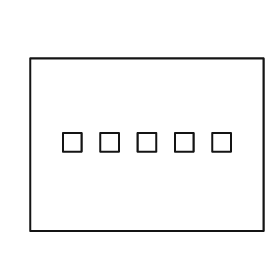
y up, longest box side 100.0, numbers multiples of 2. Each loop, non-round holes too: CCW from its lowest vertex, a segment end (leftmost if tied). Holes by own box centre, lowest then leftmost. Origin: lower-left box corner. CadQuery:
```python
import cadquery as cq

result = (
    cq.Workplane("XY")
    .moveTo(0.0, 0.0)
    .lineTo(100.0, 0.0)
    .lineTo(100.0, 74.0)
    .lineTo(0.0, 74.0)
    .close()
    .moveTo(14.0, 34.0)
    .lineTo(22.0, 34.0)
    .lineTo(22.0, 42.0)
    .lineTo(14.0, 42.0)
    .close()
    .moveTo(30.0, 34.0)
    .lineTo(38.0, 34.0)
    .lineTo(38.0, 42.0)
    .lineTo(30.0, 42.0)
    .close()
    .moveTo(46.0, 34.0)
    .lineTo(54.0, 34.0)
    .lineTo(54.0, 42.0)
    .lineTo(46.0, 42.0)
    .close()
    .moveTo(62.0, 34.0)
    .lineTo(70.0, 34.0)
    .lineTo(70.0, 42.0)
    .lineTo(62.0, 42.0)
    .close()
    .moveTo(78.0, 34.0)
    .lineTo(86.0, 34.0)
    .lineTo(86.0, 42.0)
    .lineTo(78.0, 42.0)
    .close()
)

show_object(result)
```